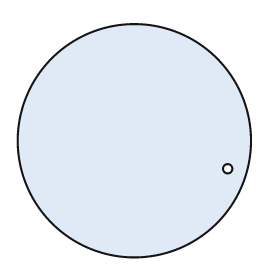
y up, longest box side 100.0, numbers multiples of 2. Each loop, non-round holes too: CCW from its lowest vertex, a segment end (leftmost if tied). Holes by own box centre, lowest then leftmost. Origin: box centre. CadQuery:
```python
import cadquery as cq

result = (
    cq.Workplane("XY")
    .moveTo(0.0, 0.0)
    .circle(50.0)
    .moveTo(40.0, -12.0)
    .circle(2.0)
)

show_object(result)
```